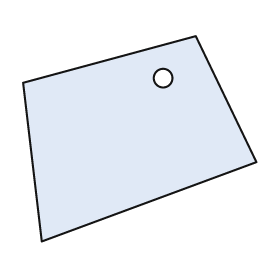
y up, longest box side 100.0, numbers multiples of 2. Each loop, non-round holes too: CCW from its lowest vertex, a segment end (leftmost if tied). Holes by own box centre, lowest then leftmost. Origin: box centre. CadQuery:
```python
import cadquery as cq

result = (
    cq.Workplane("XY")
    .moveTo(-42.0, -44.0)
    .lineTo(50.0, -10.0)
    .lineTo(24.0, 44.0)
    .lineTo(-50.0, 24.0)
    .close()
    .moveTo(10.0, 26.0)
    .circle(4.0)
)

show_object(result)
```